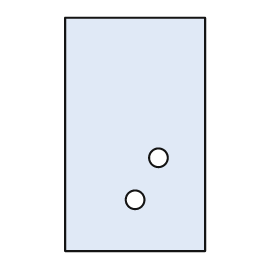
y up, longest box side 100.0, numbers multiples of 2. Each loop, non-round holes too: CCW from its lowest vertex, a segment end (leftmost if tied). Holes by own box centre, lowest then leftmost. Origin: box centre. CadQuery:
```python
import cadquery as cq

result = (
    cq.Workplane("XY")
    .moveTo(-30.0, -50.0)
    .lineTo(30.0, -50.0)
    .lineTo(30.0, 50.0)
    .lineTo(-30.0, 50.0)
    .close()
    .moveTo(0.0, -28.0)
    .circle(4.0)
    .moveTo(10.0, -10.0)
    .circle(4.0)
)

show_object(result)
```